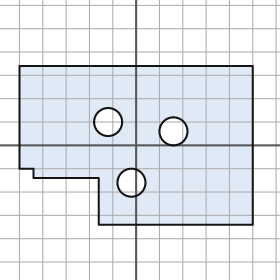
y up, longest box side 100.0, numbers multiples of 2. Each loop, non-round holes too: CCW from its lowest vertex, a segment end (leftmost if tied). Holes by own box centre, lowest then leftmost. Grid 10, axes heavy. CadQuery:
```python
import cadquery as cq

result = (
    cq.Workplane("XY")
    .moveTo(-16.0, -34.0)
    .lineTo(50.0, -34.0)
    .lineTo(50.0, 34.0)
    .lineTo(-50.0, 34.0)
    .lineTo(-50.0, -10.0)
    .lineTo(-44.0, -10.0)
    .lineTo(-44.0, -14.0)
    .lineTo(-16.0, -14.0)
    .close()
    .moveTo(-2.0, -16.0)
    .circle(6.0)
    .moveTo(16.0, 6.0)
    .circle(6.0)
    .moveTo(-12.0, 10.0)
    .circle(6.0)
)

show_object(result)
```